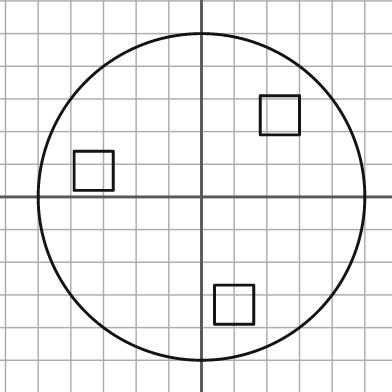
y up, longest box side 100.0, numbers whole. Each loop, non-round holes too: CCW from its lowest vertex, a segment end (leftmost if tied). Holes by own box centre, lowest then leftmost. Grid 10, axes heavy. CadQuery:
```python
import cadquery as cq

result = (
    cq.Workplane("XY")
    .moveTo(0.0, 0.0)
    .circle(50.0)
    .moveTo(4.0, -39.0)
    .lineTo(16.0, -39.0)
    .lineTo(16.0, -27.0)
    .lineTo(4.0, -27.0)
    .close()
    .moveTo(-39.0, 2.0)
    .lineTo(-27.0, 2.0)
    .lineTo(-27.0, 14.0)
    .lineTo(-39.0, 14.0)
    .close()
    .moveTo(18.0, 19.0)
    .lineTo(30.0, 19.0)
    .lineTo(30.0, 31.0)
    .lineTo(18.0, 31.0)
    .close()
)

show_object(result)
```